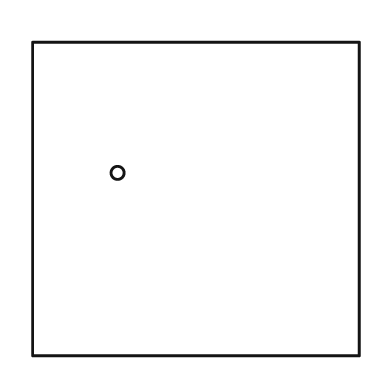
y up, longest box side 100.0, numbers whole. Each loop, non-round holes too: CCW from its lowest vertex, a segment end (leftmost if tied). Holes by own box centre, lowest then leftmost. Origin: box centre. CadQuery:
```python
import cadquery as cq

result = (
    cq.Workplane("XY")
    .moveTo(-50.0, -48.0)
    .lineTo(50.0, -48.0)
    .lineTo(50.0, 48.0)
    .lineTo(-50.0, 48.0)
    .close()
    .moveTo(-24.0, 8.0)
    .circle(2.0)
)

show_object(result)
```